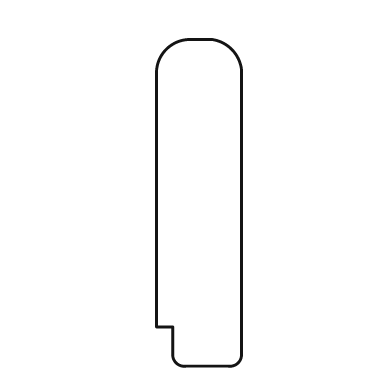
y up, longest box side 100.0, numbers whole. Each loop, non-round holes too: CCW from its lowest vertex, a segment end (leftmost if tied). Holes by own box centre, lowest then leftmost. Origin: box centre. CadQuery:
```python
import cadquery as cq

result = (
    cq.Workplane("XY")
    .moveTo(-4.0, -50.0)
    .lineTo(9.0, -50.0)
    .threePointArc((12.0, -49.0), (13.0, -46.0))
    .lineTo(13.0, 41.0)
    .threePointArc((10.0, 47.0), (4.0, 50.0))
    .lineTo(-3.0, 50.0)
    .threePointArc((-10.0, 47.0), (-13.0, 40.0))
    .lineTo(-13.0, -38.0)
    .lineTo(-8.0, -38.0)
    .lineTo(-8.0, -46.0)
    .threePointArc((-7.0, -49.0), (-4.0, -50.0))
    .close()
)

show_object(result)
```